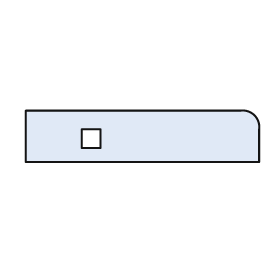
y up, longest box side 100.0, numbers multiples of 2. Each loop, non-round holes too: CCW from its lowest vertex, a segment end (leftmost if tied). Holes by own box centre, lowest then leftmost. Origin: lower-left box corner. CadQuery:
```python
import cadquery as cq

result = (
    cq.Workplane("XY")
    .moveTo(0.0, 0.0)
    .lineTo(100.0, 0.0)
    .lineTo(100.0, 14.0)
    .threePointArc((98.0, 20.0), (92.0, 22.0))
    .lineTo(0.0, 22.0)
    .close()
    .moveTo(24.0, 6.0)
    .lineTo(32.0, 6.0)
    .lineTo(32.0, 14.0)
    .lineTo(24.0, 14.0)
    .close()
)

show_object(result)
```